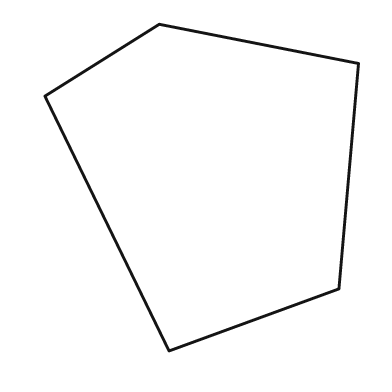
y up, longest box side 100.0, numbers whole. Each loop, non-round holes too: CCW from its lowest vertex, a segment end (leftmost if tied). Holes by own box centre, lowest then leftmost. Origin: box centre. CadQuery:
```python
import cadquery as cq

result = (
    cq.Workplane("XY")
    .moveTo(-10.0, -50.0)
    .lineTo(42.0, -31.0)
    .lineTo(48.0, 38.0)
    .lineTo(-13.0, 50.0)
    .lineTo(-48.0, 28.0)
    .close()
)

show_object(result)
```